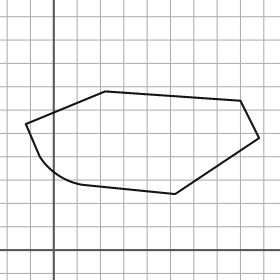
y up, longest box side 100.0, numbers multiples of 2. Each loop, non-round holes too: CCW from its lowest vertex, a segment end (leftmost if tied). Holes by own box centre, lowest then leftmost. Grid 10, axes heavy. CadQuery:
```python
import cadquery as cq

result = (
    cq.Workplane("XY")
    .moveTo(52.0, 24.0)
    .lineTo(88.0, 48.0)
    .lineTo(80.0, 64.0)
    .lineTo(22.0, 68.0)
    .lineTo(-12.0, 54.0)
    .lineTo(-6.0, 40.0)
    .threePointArc((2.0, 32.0), (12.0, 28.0))
    .close()
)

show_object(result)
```